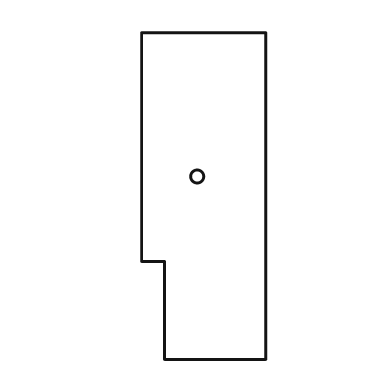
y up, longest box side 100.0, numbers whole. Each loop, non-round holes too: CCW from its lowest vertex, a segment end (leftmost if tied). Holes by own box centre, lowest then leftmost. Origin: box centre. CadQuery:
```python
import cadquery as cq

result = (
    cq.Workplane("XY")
    .moveTo(-12.0, -50.0)
    .lineTo(19.0, -50.0)
    .lineTo(19.0, 50.0)
    .lineTo(-19.0, 50.0)
    .lineTo(-19.0, -20.0)
    .lineTo(-12.0, -20.0)
    .close()
    .moveTo(-2.0, 6.0)
    .circle(2.0)
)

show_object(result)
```